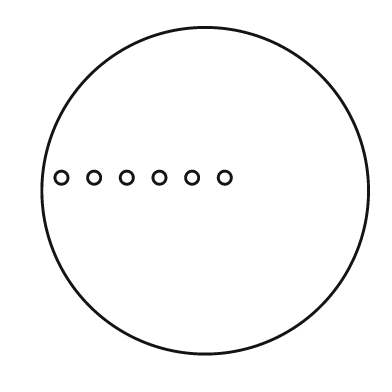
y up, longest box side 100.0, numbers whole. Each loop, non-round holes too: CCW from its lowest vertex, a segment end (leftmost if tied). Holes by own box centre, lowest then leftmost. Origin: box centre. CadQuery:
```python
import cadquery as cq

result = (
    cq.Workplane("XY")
    .moveTo(0.0, 0.0)
    .circle(50.0)
    .moveTo(-44.0, 4.0)
    .circle(2.0)
    .moveTo(-34.0, 4.0)
    .circle(2.0)
    .moveTo(-24.0, 4.0)
    .circle(2.0)
    .moveTo(-14.0, 4.0)
    .circle(2.0)
    .moveTo(-4.0, 4.0)
    .circle(2.0)
    .moveTo(6.0, 4.0)
    .circle(2.0)
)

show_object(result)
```